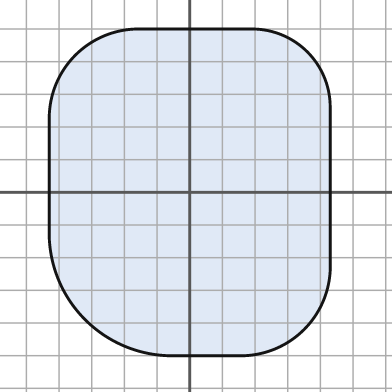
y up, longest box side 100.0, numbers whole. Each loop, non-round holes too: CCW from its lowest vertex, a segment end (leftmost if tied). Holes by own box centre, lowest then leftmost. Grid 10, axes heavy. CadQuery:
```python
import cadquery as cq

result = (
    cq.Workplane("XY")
    .moveTo(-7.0, -50.0)
    .lineTo(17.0, -50.0)
    .threePointArc((35.0, -42.0), (43.0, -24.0))
    .lineTo(43.0, 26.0)
    .threePointArc((36.0, 43.0), (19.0, 50.0))
    .lineTo(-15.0, 50.0)
    .threePointArc((-35.0, 42.0), (-43.0, 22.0))
    .lineTo(-43.0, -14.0)
    .threePointArc((-32.0, -39.0), (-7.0, -50.0))
    .close()
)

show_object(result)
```